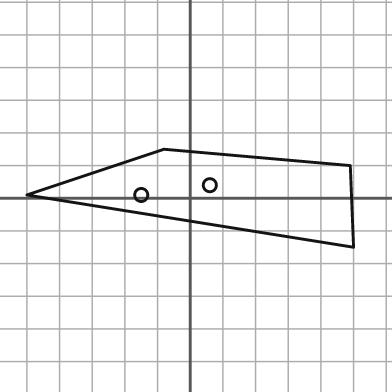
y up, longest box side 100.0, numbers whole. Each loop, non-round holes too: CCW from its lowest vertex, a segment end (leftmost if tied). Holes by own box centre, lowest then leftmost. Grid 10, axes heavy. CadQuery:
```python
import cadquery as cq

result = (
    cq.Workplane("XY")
    .moveTo(50.0, -15.0)
    .lineTo(49.0, 10.0)
    .lineTo(-8.0, 15.0)
    .lineTo(-50.0, 1.0)
    .close()
    .moveTo(-15.0, 1.0)
    .circle(2.0)
    .moveTo(6.0, 4.0)
    .circle(2.0)
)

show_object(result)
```